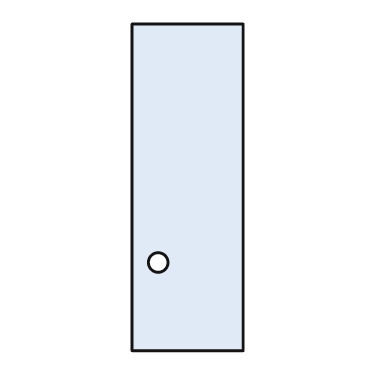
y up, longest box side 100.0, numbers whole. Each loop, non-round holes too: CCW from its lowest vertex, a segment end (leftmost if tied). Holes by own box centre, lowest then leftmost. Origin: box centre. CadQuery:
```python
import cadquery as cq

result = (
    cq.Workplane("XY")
    .moveTo(-17.0, -50.0)
    .lineTo(17.0, -50.0)
    .lineTo(17.0, 50.0)
    .lineTo(-17.0, 50.0)
    .close()
    .moveTo(-9.0, -23.0)
    .circle(3.0)
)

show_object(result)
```